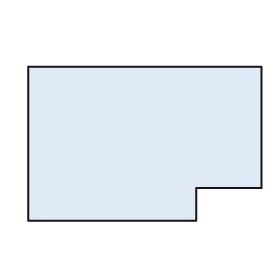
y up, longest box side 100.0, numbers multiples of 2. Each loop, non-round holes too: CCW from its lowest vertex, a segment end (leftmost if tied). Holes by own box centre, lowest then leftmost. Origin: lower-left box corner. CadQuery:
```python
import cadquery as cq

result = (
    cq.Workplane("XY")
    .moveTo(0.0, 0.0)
    .lineTo(72.0, 0.0)
    .lineTo(72.0, 14.0)
    .lineTo(100.0, 14.0)
    .lineTo(100.0, 66.0)
    .lineTo(0.0, 66.0)
    .close()
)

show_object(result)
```